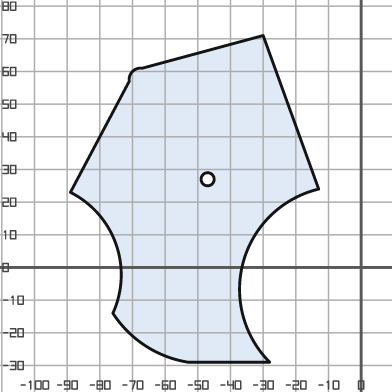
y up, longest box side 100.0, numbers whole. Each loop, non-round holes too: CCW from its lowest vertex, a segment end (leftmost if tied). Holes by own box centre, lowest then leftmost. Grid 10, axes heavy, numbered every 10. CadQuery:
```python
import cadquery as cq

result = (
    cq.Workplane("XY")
    .moveTo(-53.0, -29.0)
    .lineTo(-28.0, -29.0)
    .threePointArc((-36.0, 2.0), (-13.0, 24.0))
    .lineTo(-30.0, 71.0)
    .lineTo(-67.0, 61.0)
    .threePointArc((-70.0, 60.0), (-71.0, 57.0))
    .lineTo(-89.0, 23.0)
    .threePointArc((-75.0, 7.0), (-76.0, -14.0))
    .threePointArc((-66.0, -24.0), (-53.0, -29.0))
    .close()
    .moveTo(-47.0, 27.0)
    .circle(2.0)
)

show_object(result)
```